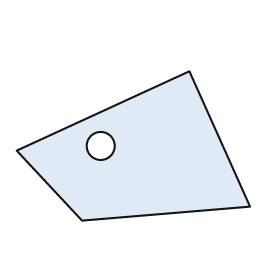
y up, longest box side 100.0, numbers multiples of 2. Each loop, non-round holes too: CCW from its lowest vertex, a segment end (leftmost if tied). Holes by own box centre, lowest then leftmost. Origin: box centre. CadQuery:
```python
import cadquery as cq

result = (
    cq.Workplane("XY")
    .moveTo(-22.0, -32.0)
    .lineTo(50.0, -26.0)
    .lineTo(24.0, 32.0)
    .lineTo(-50.0, -2.0)
    .close()
    .moveTo(-14.0, 0.0)
    .circle(6.0)
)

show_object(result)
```